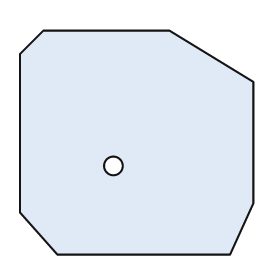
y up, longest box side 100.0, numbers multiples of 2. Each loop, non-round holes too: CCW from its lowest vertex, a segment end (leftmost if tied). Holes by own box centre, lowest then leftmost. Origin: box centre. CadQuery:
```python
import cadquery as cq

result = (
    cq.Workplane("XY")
    .moveTo(-34.0, -48.0)
    .lineTo(40.0, -48.0)
    .lineTo(50.0, -26.0)
    .lineTo(50.0, 26.0)
    .lineTo(14.0, 48.0)
    .lineTo(-40.0, 48.0)
    .lineTo(-50.0, 38.0)
    .lineTo(-50.0, -30.0)
    .close()
    .moveTo(-10.0, -10.0)
    .circle(4.0)
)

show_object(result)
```